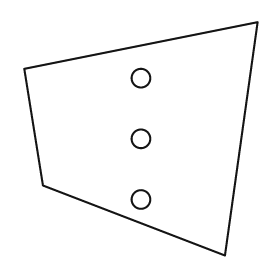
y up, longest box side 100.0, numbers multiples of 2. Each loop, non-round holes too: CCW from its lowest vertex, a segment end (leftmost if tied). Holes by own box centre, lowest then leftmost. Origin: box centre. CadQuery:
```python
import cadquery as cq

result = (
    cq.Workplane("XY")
    .moveTo(36.0, -50.0)
    .lineTo(50.0, 50.0)
    .lineTo(-50.0, 30.0)
    .lineTo(-42.0, -20.0)
    .close()
    .moveTo(0.0, -26.0)
    .circle(4.0)
    .moveTo(0.0, 0.0)
    .circle(4.0)
    .moveTo(0.0, 26.0)
    .circle(4.0)
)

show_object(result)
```